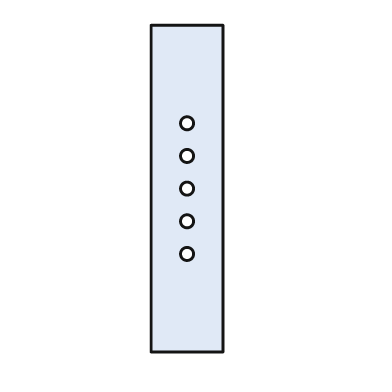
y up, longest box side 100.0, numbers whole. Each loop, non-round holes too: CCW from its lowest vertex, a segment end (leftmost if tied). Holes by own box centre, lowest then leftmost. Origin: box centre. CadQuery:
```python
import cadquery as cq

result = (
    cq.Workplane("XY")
    .moveTo(-11.0, -50.0)
    .lineTo(11.0, -50.0)
    .lineTo(11.0, 50.0)
    .lineTo(-11.0, 50.0)
    .close()
    .moveTo(0.0, -20.0)
    .circle(2.0)
    .moveTo(0.0, -10.0)
    .circle(2.0)
    .moveTo(0.0, 0.0)
    .circle(2.0)
    .moveTo(0.0, 10.0)
    .circle(2.0)
    .moveTo(0.0, 20.0)
    .circle(2.0)
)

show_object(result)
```